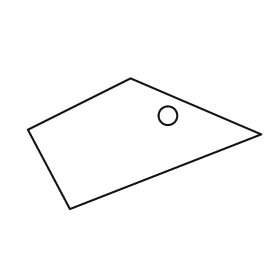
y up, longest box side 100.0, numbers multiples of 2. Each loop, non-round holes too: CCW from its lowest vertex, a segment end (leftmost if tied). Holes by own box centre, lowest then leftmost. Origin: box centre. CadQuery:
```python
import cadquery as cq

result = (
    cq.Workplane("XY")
    .moveTo(-32.0, -28.0)
    .lineTo(50.0, 4.0)
    .lineTo(-6.0, 28.0)
    .lineTo(-50.0, 6.0)
    .close()
    .moveTo(10.0, 12.0)
    .circle(4.0)
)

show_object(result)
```